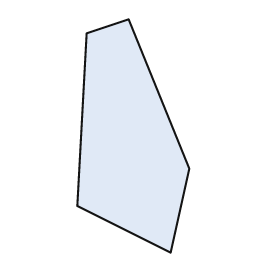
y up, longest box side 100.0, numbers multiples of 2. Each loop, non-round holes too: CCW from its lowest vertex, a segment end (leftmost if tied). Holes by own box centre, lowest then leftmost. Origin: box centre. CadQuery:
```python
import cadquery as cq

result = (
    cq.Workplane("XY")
    .moveTo(16.0, -50.0)
    .lineTo(24.0, -14.0)
    .lineTo(-2.0, 50.0)
    .lineTo(-20.0, 44.0)
    .lineTo(-24.0, -30.0)
    .close()
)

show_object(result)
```